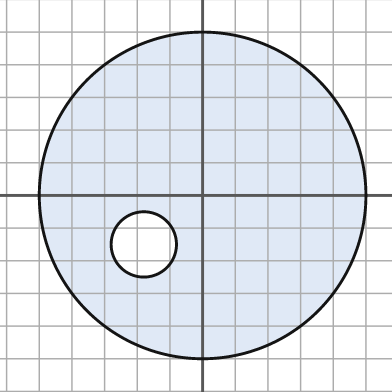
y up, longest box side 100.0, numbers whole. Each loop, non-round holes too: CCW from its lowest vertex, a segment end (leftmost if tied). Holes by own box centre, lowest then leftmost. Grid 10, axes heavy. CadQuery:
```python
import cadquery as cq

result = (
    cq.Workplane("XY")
    .moveTo(0.0, 0.0)
    .circle(50.0)
    .moveTo(-18.0, -15.0)
    .circle(10.0)
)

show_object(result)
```